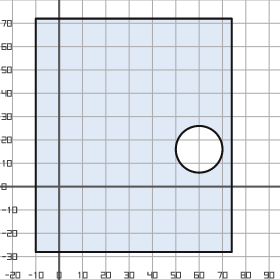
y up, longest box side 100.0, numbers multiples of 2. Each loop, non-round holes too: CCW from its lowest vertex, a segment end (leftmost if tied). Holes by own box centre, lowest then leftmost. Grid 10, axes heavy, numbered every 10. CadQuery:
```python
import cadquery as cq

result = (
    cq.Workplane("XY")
    .moveTo(-10.0, -28.0)
    .lineTo(74.0, -28.0)
    .lineTo(74.0, 72.0)
    .lineTo(-10.0, 72.0)
    .close()
    .moveTo(60.0, 16.0)
    .circle(10.0)
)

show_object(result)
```